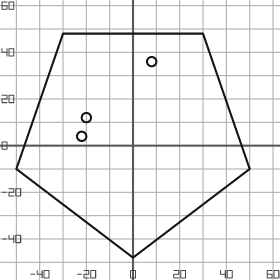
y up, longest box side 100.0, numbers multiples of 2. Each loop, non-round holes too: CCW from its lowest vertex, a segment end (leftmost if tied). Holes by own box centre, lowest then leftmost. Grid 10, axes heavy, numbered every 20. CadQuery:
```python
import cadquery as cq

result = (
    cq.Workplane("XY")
    .moveTo(0.0, -48.0)
    .lineTo(50.0, -10.0)
    .lineTo(30.0, 48.0)
    .lineTo(-30.0, 48.0)
    .lineTo(-50.0, -10.0)
    .close()
    .moveTo(-22.0, 4.0)
    .circle(2.0)
    .moveTo(-20.0, 12.0)
    .circle(2.0)
    .moveTo(8.0, 36.0)
    .circle(2.0)
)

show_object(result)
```